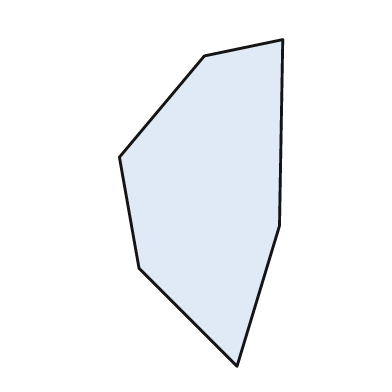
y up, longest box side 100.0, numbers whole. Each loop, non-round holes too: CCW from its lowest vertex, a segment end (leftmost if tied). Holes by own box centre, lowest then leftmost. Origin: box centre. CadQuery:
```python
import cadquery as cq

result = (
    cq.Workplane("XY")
    .moveTo(11.0, -50.0)
    .lineTo(24.0, -7.0)
    .lineTo(25.0, 50.0)
    .lineTo(1.0, 45.0)
    .lineTo(-25.0, 14.0)
    .lineTo(-19.0, -20.0)
    .close()
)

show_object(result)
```